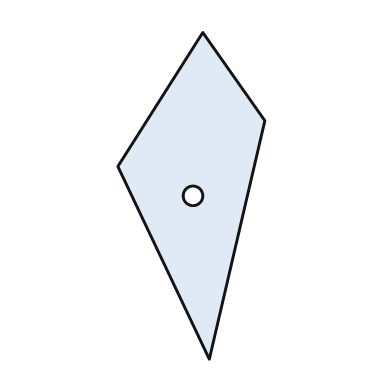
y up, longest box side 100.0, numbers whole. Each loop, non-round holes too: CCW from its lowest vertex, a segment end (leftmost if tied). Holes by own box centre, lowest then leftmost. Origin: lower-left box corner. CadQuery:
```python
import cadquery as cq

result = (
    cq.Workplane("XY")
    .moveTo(28.0, 0.0)
    .lineTo(45.0, 73.0)
    .lineTo(26.0, 100.0)
    .lineTo(0.0, 59.0)
    .close()
    .moveTo(23.0, 50.0)
    .circle(3.0)
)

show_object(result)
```